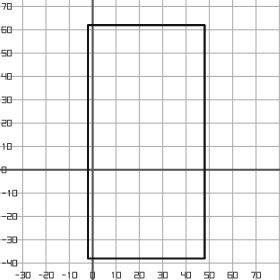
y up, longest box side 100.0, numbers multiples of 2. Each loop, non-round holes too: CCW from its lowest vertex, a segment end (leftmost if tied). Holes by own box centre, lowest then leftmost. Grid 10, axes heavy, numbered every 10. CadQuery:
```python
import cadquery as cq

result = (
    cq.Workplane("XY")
    .moveTo(-2.0, -38.0)
    .lineTo(48.0, -38.0)
    .lineTo(48.0, 62.0)
    .lineTo(-2.0, 62.0)
    .close()
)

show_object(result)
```